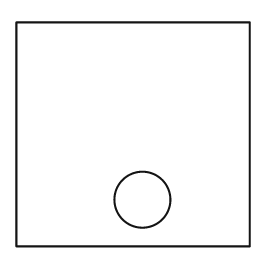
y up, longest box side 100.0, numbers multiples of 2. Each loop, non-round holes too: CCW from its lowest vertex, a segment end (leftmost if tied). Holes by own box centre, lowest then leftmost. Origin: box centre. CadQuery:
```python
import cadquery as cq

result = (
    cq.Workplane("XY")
    .moveTo(-50.0, -48.0)
    .lineTo(50.0, -48.0)
    .lineTo(50.0, 48.0)
    .lineTo(-50.0, 48.0)
    .close()
    .moveTo(4.0, -28.0)
    .circle(12.0)
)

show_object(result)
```